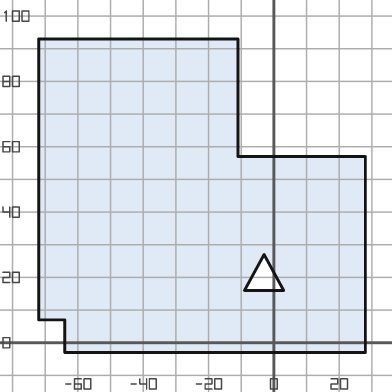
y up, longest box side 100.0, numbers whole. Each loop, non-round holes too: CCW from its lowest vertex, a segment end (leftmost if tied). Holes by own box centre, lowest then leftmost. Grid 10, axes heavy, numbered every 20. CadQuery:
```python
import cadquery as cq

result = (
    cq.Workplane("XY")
    .moveTo(-64.0, -3.0)
    .lineTo(28.0, -3.0)
    .lineTo(28.0, 57.0)
    .lineTo(-11.0, 57.0)
    .lineTo(-11.0, 93.0)
    .lineTo(-72.0, 93.0)
    .lineTo(-72.0, 7.0)
    .lineTo(-64.0, 7.0)
    .close()
    .moveTo(-9.0, 16.0)
    .lineTo(3.0, 16.0)
    .lineTo(-3.0, 27.0)
    .close()
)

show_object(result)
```